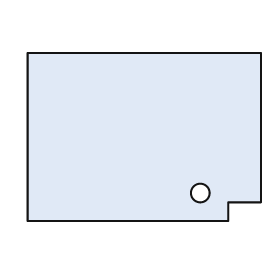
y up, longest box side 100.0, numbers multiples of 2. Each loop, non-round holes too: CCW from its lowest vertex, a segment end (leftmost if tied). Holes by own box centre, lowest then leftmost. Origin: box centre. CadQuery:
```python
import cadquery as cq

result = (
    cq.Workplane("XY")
    .moveTo(-50.0, -36.0)
    .lineTo(36.0, -36.0)
    .lineTo(36.0, -28.0)
    .lineTo(50.0, -28.0)
    .lineTo(50.0, 36.0)
    .lineTo(-50.0, 36.0)
    .close()
    .moveTo(24.0, -24.0)
    .circle(4.0)
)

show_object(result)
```